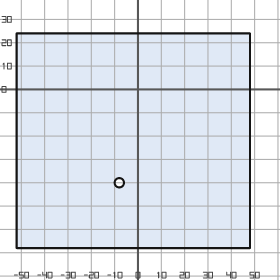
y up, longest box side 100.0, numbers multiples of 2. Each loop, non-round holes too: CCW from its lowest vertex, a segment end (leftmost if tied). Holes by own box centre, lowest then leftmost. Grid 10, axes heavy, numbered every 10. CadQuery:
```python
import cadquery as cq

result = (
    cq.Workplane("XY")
    .moveTo(-52.0, -68.0)
    .lineTo(48.0, -68.0)
    .lineTo(48.0, 24.0)
    .lineTo(-52.0, 24.0)
    .close()
    .moveTo(-8.0, -40.0)
    .circle(2.0)
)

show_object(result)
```